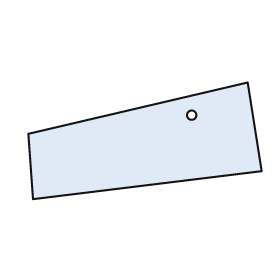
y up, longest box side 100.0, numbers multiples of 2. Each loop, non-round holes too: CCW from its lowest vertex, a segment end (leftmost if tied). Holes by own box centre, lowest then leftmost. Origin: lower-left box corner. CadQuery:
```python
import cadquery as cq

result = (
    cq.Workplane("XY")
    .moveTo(2.0, 0.0)
    .lineTo(100.0, 12.0)
    .lineTo(94.0, 50.0)
    .lineTo(0.0, 28.0)
    .close()
    .moveTo(70.0, 36.0)
    .circle(2.0)
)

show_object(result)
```